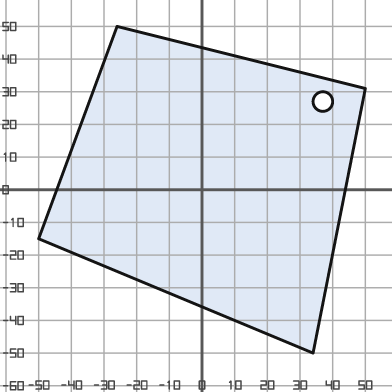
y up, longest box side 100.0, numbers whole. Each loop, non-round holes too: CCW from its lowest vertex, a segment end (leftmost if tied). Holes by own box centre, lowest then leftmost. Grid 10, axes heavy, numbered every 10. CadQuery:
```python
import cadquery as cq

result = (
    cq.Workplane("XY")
    .moveTo(34.0, -50.0)
    .lineTo(50.0, 31.0)
    .lineTo(-26.0, 50.0)
    .lineTo(-50.0, -15.0)
    .close()
    .moveTo(37.0, 27.0)
    .circle(3.0)
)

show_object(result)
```